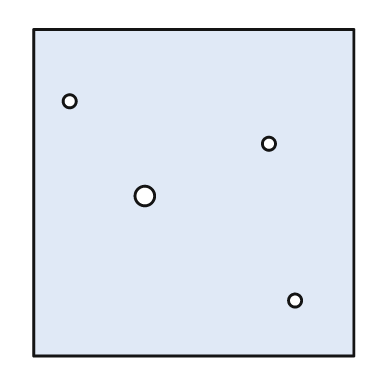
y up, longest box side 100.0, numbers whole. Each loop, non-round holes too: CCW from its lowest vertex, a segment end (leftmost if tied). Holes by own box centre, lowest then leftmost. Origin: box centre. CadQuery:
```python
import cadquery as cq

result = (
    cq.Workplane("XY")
    .moveTo(-49.0, -50.0)
    .lineTo(49.0, -50.0)
    .lineTo(49.0, 50.0)
    .lineTo(-49.0, 50.0)
    .close()
    .moveTo(31.0, -33.0)
    .circle(2.0)
    .moveTo(-15.0, -1.0)
    .circle(3.0)
    .moveTo(23.0, 15.0)
    .circle(2.0)
    .moveTo(-38.0, 28.0)
    .circle(2.0)
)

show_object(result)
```